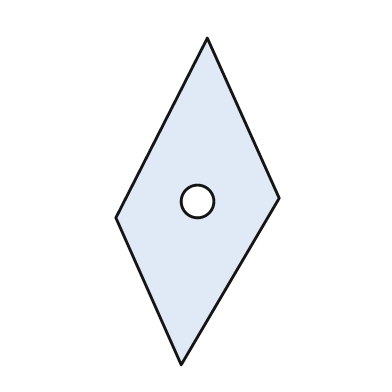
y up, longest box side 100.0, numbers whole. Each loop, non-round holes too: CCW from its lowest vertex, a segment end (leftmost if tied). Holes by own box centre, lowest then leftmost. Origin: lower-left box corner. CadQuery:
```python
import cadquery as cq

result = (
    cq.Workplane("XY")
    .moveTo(20.0, 0.0)
    .lineTo(50.0, 51.0)
    .lineTo(28.0, 100.0)
    .lineTo(0.0, 45.0)
    .close()
    .moveTo(25.0, 50.0)
    .circle(5.0)
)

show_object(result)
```